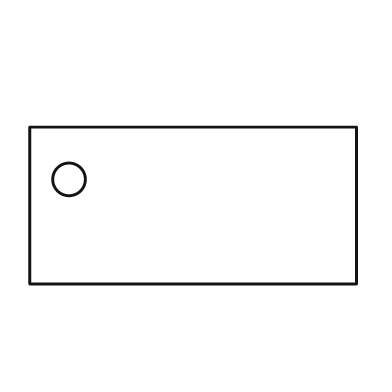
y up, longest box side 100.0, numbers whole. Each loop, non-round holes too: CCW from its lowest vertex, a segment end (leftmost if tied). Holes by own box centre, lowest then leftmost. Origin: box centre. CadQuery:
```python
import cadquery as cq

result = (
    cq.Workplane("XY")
    .moveTo(-50.0, -24.0)
    .lineTo(50.0, -24.0)
    .lineTo(50.0, 24.0)
    .lineTo(-50.0, 24.0)
    .close()
    .moveTo(-38.0, 8.0)
    .circle(5.0)
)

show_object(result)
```